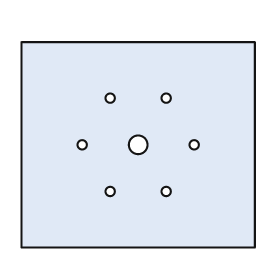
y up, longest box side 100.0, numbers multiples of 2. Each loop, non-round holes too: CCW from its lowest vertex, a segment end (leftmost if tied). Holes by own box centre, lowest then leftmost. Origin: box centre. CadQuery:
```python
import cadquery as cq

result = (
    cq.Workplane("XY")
    .moveTo(-50.0, -44.0)
    .lineTo(50.0, -44.0)
    .lineTo(50.0, 44.0)
    .lineTo(-50.0, 44.0)
    .close()
    .moveTo(-12.0, -20.0)
    .circle(2.0)
    .moveTo(12.0, -20.0)
    .circle(2.0)
    .moveTo(-24.0, 0.0)
    .circle(2.0)
    .moveTo(0.0, 0.0)
    .circle(4.0)
    .moveTo(24.0, 0.0)
    .circle(2.0)
    .moveTo(-12.0, 20.0)
    .circle(2.0)
    .moveTo(12.0, 20.0)
    .circle(2.0)
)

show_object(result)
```